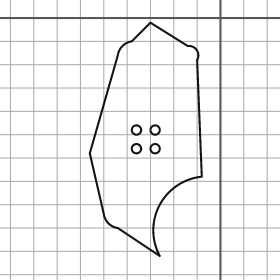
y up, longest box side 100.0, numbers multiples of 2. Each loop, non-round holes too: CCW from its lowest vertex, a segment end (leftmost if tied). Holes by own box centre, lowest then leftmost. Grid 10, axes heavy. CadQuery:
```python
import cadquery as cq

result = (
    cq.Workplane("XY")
    .moveTo(-26.0, -102.0)
    .threePointArc((-26.0, -80.0), (-8.0, -68.0))
    .lineTo(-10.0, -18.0)
    .threePointArc((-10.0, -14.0), (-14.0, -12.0))
    .lineTo(-30.0, -2.0)
    .lineTo(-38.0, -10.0)
    .threePointArc((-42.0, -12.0), (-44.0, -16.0))
    .lineTo(-56.0, -58.0)
    .lineTo(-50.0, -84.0)
    .threePointArc((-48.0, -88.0), (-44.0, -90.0))
    .close()
    .moveTo(-36.0, -56.0)
    .circle(2.0)
    .moveTo(-28.0, -56.0)
    .circle(2.0)
    .moveTo(-36.0, -48.0)
    .circle(2.0)
    .moveTo(-28.0, -48.0)
    .circle(2.0)
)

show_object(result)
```